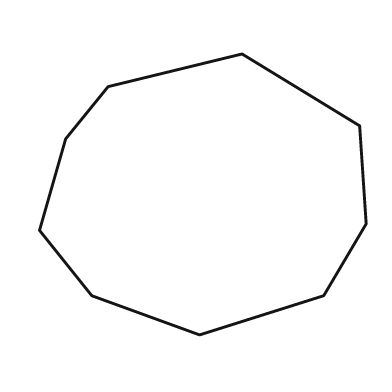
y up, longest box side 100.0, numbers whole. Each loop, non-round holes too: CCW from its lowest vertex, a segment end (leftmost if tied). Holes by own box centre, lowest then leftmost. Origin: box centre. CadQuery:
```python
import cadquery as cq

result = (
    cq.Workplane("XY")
    .moveTo(-1.0, -43.0)
    .lineTo(37.0, -31.0)
    .lineTo(50.0, -9.0)
    .lineTo(48.0, 21.0)
    .lineTo(12.0, 43.0)
    .lineTo(-29.0, 33.0)
    .lineTo(-42.0, 17.0)
    .lineTo(-50.0, -11.0)
    .lineTo(-34.0, -31.0)
    .close()
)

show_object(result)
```